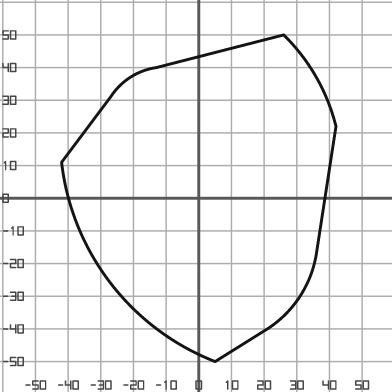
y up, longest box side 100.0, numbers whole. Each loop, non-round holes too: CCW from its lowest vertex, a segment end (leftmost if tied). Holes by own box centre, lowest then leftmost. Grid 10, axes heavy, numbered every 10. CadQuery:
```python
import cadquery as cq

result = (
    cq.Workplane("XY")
    .moveTo(5.0, -50.0)
    .lineTo(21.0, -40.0)
    .threePointArc((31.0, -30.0), (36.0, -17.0))
    .lineTo(42.0, 22.0)
    .threePointArc((36.0, 37.0), (26.0, 50.0))
    .lineTo(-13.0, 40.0)
    .threePointArc((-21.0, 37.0), (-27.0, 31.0))
    .lineTo(-42.0, 11.0)
    .threePointArc((-27.0, -26.0), (5.0, -50.0))
    .close()
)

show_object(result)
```